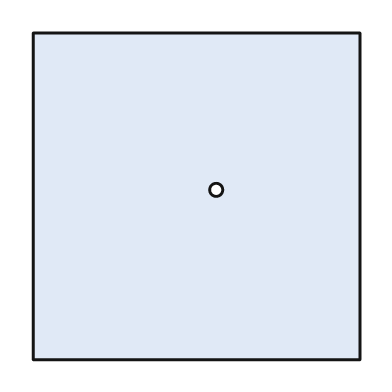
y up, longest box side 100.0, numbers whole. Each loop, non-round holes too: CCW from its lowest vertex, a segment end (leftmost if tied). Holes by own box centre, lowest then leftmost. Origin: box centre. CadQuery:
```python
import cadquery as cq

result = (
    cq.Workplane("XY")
    .moveTo(-50.0, -50.0)
    .lineTo(50.0, -50.0)
    .lineTo(50.0, 50.0)
    .lineTo(-50.0, 50.0)
    .close()
    .moveTo(6.0, 2.0)
    .circle(2.0)
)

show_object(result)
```